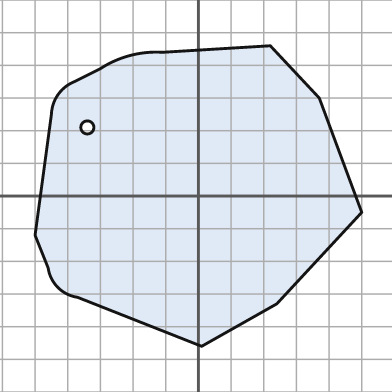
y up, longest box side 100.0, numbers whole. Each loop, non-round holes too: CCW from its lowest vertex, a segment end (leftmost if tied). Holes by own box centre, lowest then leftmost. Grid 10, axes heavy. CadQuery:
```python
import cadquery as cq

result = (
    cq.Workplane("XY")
    .moveTo(1.0, -46.0)
    .lineTo(24.0, -33.0)
    .lineTo(50.0, -5.0)
    .lineTo(37.0, 30.0)
    .lineTo(22.0, 46.0)
    .lineTo(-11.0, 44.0)
    .threePointArc((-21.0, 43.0), (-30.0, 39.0))
    .lineTo(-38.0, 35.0)
    .threePointArc((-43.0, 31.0), (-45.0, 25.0))
    .lineTo(-50.0, -12.0)
    .lineTo(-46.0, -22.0)
    .threePointArc((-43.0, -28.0), (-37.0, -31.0))
    .close()
    .moveTo(-34.0, 21.0)
    .circle(2.0)
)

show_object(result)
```